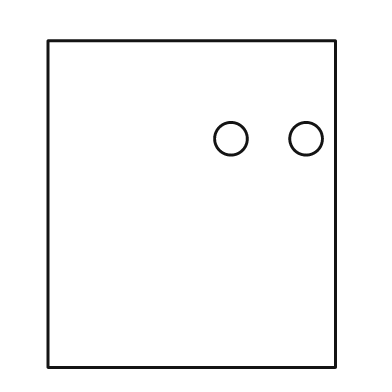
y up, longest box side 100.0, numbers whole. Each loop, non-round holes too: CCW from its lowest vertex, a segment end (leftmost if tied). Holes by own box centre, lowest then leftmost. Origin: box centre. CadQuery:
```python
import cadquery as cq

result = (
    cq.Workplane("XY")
    .moveTo(-44.0, -50.0)
    .lineTo(44.0, -50.0)
    .lineTo(44.0, 50.0)
    .lineTo(-44.0, 50.0)
    .close()
    .moveTo(12.0, 20.0)
    .circle(5.0)
    .moveTo(35.0, 20.0)
    .circle(5.0)
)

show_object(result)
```